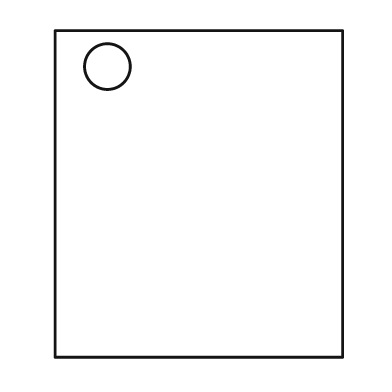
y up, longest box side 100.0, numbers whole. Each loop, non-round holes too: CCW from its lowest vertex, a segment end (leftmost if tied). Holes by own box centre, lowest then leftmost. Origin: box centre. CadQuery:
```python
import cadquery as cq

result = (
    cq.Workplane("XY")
    .moveTo(-44.0, -50.0)
    .lineTo(44.0, -50.0)
    .lineTo(44.0, 50.0)
    .lineTo(-44.0, 50.0)
    .close()
    .moveTo(-28.0, 39.0)
    .circle(7.0)
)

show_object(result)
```